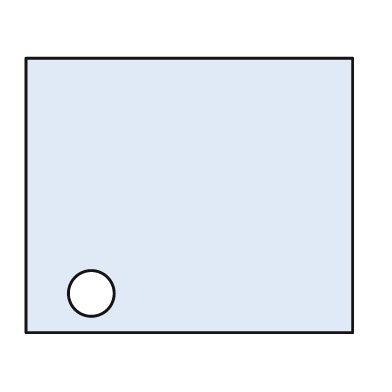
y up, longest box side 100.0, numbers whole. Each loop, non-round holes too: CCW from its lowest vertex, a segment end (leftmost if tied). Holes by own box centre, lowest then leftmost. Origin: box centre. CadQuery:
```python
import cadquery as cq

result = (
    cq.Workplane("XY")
    .moveTo(-50.0, -42.0)
    .lineTo(50.0, -42.0)
    .lineTo(50.0, 42.0)
    .lineTo(-50.0, 42.0)
    .close()
    .moveTo(-30.0, -30.0)
    .circle(7.0)
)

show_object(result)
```